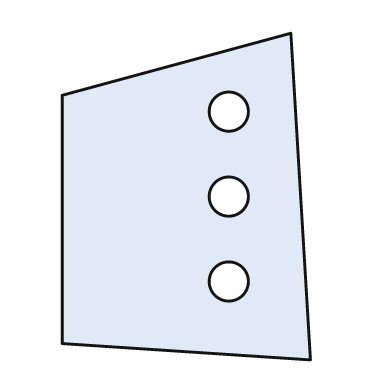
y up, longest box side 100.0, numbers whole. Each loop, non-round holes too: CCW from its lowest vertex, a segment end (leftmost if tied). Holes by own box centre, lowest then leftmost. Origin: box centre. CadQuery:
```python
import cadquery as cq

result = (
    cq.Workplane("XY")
    .moveTo(38.0, -50.0)
    .lineTo(32.0, 50.0)
    .lineTo(-38.0, 31.0)
    .lineTo(-38.0, -45.0)
    .close()
    .moveTo(13.0, -26.0)
    .circle(6.0)
    .moveTo(13.0, 0.0)
    .circle(6.0)
    .moveTo(13.0, 26.0)
    .circle(6.0)
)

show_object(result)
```